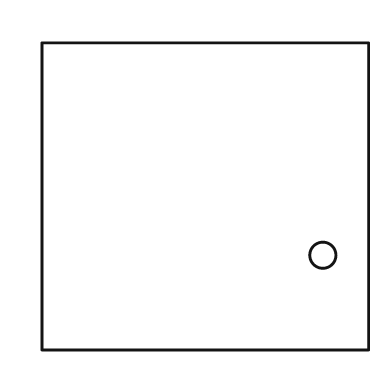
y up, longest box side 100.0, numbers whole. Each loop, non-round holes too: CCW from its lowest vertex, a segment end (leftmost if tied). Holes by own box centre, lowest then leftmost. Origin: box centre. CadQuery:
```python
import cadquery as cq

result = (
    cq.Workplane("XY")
    .moveTo(-50.0, -47.0)
    .lineTo(50.0, -47.0)
    .lineTo(50.0, 47.0)
    .lineTo(-50.0, 47.0)
    .close()
    .moveTo(36.0, -18.0)
    .circle(4.0)
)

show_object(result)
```